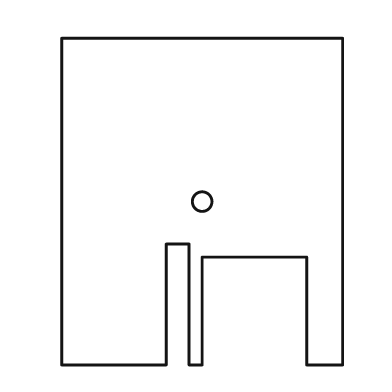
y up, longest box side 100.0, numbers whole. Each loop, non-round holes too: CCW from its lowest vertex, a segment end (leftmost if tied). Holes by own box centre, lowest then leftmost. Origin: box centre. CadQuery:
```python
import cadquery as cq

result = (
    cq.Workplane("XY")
    .moveTo(-43.0, -50.0)
    .lineTo(-11.0, -50.0)
    .lineTo(-11.0, -13.0)
    .lineTo(-4.0, -13.0)
    .lineTo(-4.0, -50.0)
    .lineTo(0.0, -50.0)
    .lineTo(0.0, -17.0)
    .lineTo(32.0, -17.0)
    .lineTo(32.0, -50.0)
    .lineTo(43.0, -50.0)
    .lineTo(43.0, 50.0)
    .lineTo(-43.0, 50.0)
    .close()
    .moveTo(0.0, 0.0)
    .circle(3.0)
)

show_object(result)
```